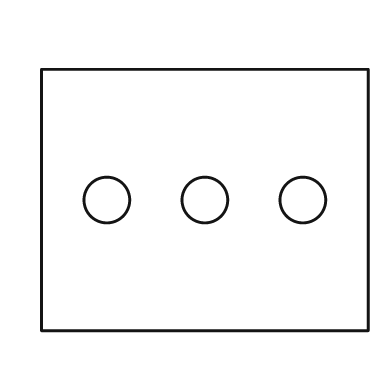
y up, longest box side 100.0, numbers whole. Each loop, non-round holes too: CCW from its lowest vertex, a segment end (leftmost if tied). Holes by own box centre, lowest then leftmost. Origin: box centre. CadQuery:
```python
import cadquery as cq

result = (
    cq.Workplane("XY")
    .moveTo(-50.0, -40.0)
    .lineTo(50.0, -40.0)
    .lineTo(50.0, 40.0)
    .lineTo(-50.0, 40.0)
    .close()
    .moveTo(-30.0, 0.0)
    .circle(7.0)
    .moveTo(0.0, 0.0)
    .circle(7.0)
    .moveTo(30.0, 0.0)
    .circle(7.0)
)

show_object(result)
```